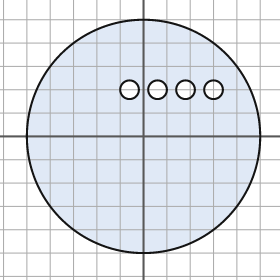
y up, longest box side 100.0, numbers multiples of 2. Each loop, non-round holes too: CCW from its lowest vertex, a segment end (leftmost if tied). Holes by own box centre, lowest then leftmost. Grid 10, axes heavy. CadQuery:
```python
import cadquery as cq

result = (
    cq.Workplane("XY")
    .moveTo(0.0, 0.0)
    .circle(50.0)
    .moveTo(-6.0, 20.0)
    .circle(4.0)
    .moveTo(6.0, 20.0)
    .circle(4.0)
    .moveTo(18.0, 20.0)
    .circle(4.0)
    .moveTo(30.0, 20.0)
    .circle(4.0)
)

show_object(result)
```